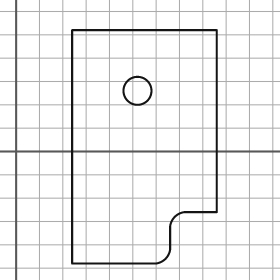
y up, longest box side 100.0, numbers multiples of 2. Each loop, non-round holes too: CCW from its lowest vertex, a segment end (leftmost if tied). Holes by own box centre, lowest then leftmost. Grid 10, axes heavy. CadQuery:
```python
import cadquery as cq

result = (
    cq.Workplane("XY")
    .moveTo(24.0, -48.0)
    .lineTo(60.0, -48.0)
    .threePointArc((64.0, -46.0), (66.0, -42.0))
    .lineTo(66.0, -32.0)
    .threePointArc((68.0, -28.0), (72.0, -26.0))
    .lineTo(86.0, -26.0)
    .lineTo(86.0, 52.0)
    .lineTo(24.0, 52.0)
    .close()
    .moveTo(52.0, 26.0)
    .circle(6.0)
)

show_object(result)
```